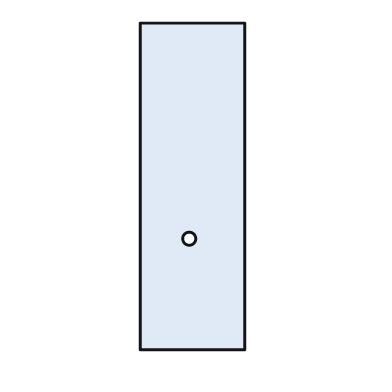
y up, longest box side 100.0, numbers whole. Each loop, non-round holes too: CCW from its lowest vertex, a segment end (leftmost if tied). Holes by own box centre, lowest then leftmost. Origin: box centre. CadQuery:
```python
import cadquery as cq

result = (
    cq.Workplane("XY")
    .moveTo(-16.0, -50.0)
    .lineTo(16.0, -50.0)
    .lineTo(16.0, 50.0)
    .lineTo(-16.0, 50.0)
    .close()
    .moveTo(-1.0, -16.0)
    .circle(2.0)
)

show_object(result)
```